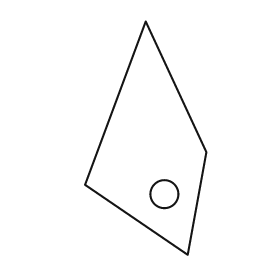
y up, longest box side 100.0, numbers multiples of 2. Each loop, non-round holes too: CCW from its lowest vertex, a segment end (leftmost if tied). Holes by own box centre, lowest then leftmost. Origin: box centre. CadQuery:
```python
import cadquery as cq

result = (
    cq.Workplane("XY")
    .moveTo(18.0, -50.0)
    .lineTo(26.0, -6.0)
    .lineTo(0.0, 50.0)
    .lineTo(-26.0, -20.0)
    .close()
    .moveTo(8.0, -24.0)
    .circle(6.0)
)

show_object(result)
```